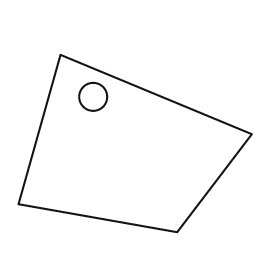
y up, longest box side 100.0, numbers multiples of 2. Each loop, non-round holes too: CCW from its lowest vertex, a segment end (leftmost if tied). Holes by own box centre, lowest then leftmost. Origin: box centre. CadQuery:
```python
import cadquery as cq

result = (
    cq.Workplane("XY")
    .moveTo(18.0, -38.0)
    .lineTo(50.0, 4.0)
    .lineTo(-32.0, 38.0)
    .lineTo(-50.0, -26.0)
    .close()
    .moveTo(-18.0, 20.0)
    .circle(6.0)
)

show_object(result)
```